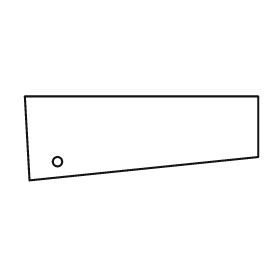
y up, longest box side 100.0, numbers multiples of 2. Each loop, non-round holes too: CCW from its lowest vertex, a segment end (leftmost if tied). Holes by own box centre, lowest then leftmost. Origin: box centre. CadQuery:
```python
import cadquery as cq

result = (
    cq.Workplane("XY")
    .moveTo(-48.0, -18.0)
    .lineTo(50.0, -8.0)
    .lineTo(50.0, 18.0)
    .lineTo(-50.0, 18.0)
    .close()
    .moveTo(-36.0, -10.0)
    .circle(2.0)
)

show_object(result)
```